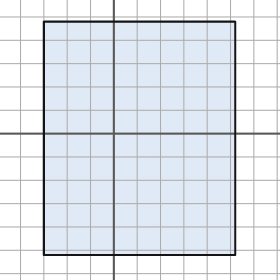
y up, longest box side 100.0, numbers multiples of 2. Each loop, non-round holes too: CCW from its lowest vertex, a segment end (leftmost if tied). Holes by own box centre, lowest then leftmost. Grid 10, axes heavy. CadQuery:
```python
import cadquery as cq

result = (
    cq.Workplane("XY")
    .moveTo(-30.0, -52.0)
    .lineTo(52.0, -52.0)
    .lineTo(52.0, 48.0)
    .lineTo(-30.0, 48.0)
    .close()
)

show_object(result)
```